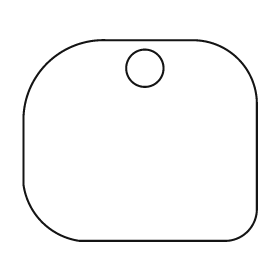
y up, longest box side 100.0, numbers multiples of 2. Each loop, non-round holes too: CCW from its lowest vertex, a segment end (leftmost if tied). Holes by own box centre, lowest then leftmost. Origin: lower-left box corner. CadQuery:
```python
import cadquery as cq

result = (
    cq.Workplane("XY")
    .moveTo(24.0, 0.0)
    .lineTo(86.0, 0.0)
    .threePointArc((96.0, 4.0), (100.0, 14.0))
    .lineTo(100.0, 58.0)
    .threePointArc((92.0, 78.0), (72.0, 86.0))
    .lineTo(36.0, 86.0)
    .threePointArc((10.0, 76.0), (0.0, 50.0))
    .lineTo(0.0, 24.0)
    .threePointArc((8.0, 8.0), (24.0, 0.0))
    .close()
    .moveTo(52.0, 74.0)
    .circle(8.0)
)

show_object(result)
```